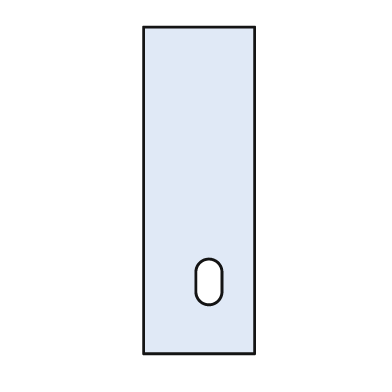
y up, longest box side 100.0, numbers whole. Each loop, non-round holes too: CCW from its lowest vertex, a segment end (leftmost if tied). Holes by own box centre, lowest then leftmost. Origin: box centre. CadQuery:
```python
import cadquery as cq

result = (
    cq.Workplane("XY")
    .moveTo(-17.0, -50.0)
    .lineTo(17.0, -50.0)
    .lineTo(17.0, 50.0)
    .lineTo(-17.0, 50.0)
    .close()
    .moveTo(-1.0, -31.0)
    .threePointArc((3.0, -35.0), (7.0, -31.0))
    .lineTo(7.0, -25.0)
    .threePointArc((3.0, -21.0), (-1.0, -25.0))
    .close()
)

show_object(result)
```